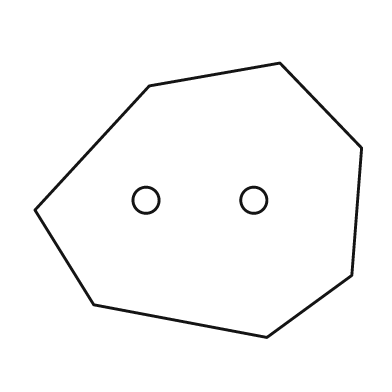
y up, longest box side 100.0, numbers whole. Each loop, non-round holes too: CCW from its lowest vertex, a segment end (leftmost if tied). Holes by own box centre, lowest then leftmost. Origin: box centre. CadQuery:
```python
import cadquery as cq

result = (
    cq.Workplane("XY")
    .moveTo(21.0, -42.0)
    .lineTo(47.0, -23.0)
    .lineTo(50.0, 16.0)
    .lineTo(25.0, 42.0)
    .lineTo(-15.0, 35.0)
    .lineTo(-50.0, -3.0)
    .lineTo(-32.0, -32.0)
    .close()
    .moveTo(-16.0, 0.0)
    .circle(4.0)
    .moveTo(17.0, 0.0)
    .circle(4.0)
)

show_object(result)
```